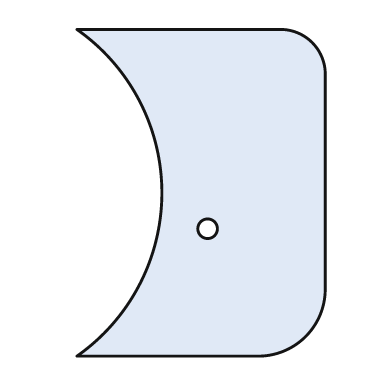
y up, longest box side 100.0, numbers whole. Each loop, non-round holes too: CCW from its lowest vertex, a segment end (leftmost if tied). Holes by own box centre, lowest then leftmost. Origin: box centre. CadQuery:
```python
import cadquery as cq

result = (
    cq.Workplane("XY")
    .moveTo(-38.0, -50.0)
    .lineTo(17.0, -50.0)
    .threePointArc((32.0, -44.0), (38.0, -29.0))
    .lineTo(38.0, 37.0)
    .threePointArc((34.0, 46.0), (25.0, 50.0))
    .lineTo(-38.0, 50.0)
    .threePointArc((-12.0, 0.0), (-38.0, -50.0))
    .close()
    .moveTo(2.0, -11.0)
    .circle(3.0)
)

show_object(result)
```